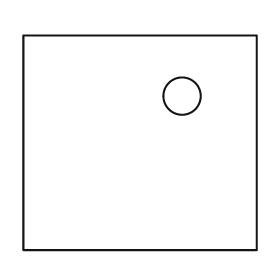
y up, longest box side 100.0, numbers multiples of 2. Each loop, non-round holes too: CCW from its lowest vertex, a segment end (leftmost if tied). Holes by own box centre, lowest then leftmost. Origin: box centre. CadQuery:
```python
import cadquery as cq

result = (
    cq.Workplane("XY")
    .moveTo(-50.0, -46.0)
    .lineTo(50.0, -46.0)
    .lineTo(50.0, 46.0)
    .lineTo(-50.0, 46.0)
    .close()
    .moveTo(18.0, 20.0)
    .circle(8.0)
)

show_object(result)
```